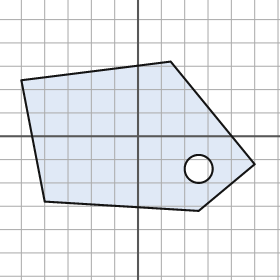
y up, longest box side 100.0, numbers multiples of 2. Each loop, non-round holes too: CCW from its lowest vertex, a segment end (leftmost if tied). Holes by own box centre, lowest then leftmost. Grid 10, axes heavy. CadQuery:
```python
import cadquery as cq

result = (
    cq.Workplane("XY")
    .moveTo(26.0, -32.0)
    .lineTo(50.0, -12.0)
    .lineTo(14.0, 32.0)
    .lineTo(-50.0, 24.0)
    .lineTo(-40.0, -28.0)
    .close()
    .moveTo(26.0, -14.0)
    .circle(6.0)
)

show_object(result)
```